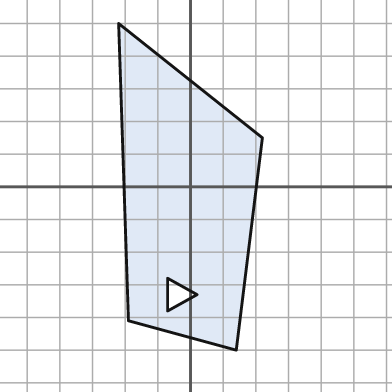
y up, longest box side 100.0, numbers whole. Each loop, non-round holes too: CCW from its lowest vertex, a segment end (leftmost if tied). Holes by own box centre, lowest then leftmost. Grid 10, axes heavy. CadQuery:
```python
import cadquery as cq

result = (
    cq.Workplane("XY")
    .moveTo(14.0, -50.0)
    .lineTo(22.0, 15.0)
    .lineTo(-22.0, 50.0)
    .lineTo(-19.0, -41.0)
    .close()
    .moveTo(-7.0, -38.0)
    .lineTo(2.0, -33.0)
    .lineTo(-7.0, -28.0)
    .close()
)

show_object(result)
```